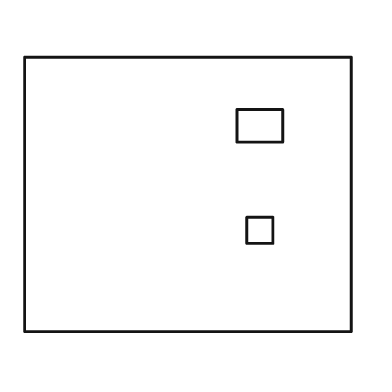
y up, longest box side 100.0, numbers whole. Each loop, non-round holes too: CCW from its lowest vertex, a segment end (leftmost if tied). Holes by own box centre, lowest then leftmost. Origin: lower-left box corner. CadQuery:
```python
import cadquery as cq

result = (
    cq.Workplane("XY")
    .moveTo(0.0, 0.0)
    .lineTo(100.0, 0.0)
    .lineTo(100.0, 84.0)
    .lineTo(0.0, 84.0)
    .close()
    .moveTo(68.0, 27.0)
    .lineTo(76.0, 27.0)
    .lineTo(76.0, 35.0)
    .lineTo(68.0, 35.0)
    .close()
    .moveTo(65.0, 58.0)
    .lineTo(79.0, 58.0)
    .lineTo(79.0, 68.0)
    .lineTo(65.0, 68.0)
    .close()
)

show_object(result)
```